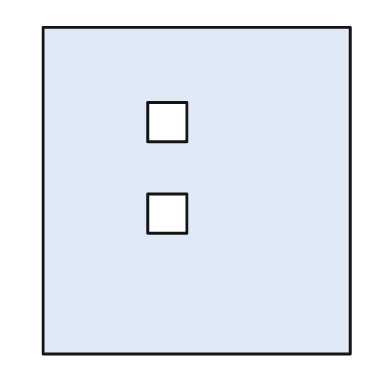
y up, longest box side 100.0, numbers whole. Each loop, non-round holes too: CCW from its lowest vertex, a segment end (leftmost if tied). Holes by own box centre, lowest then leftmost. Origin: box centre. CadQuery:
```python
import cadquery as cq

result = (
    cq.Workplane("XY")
    .moveTo(-47.0, -50.0)
    .lineTo(47.0, -50.0)
    .lineTo(47.0, 50.0)
    .lineTo(-47.0, 50.0)
    .close()
    .moveTo(-15.0, -13.0)
    .lineTo(-3.0, -13.0)
    .lineTo(-3.0, -1.0)
    .lineTo(-15.0, -1.0)
    .close()
    .moveTo(-15.0, 15.0)
    .lineTo(-3.0, 15.0)
    .lineTo(-3.0, 27.0)
    .lineTo(-15.0, 27.0)
    .close()
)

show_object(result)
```